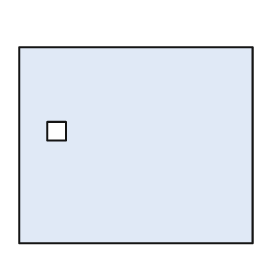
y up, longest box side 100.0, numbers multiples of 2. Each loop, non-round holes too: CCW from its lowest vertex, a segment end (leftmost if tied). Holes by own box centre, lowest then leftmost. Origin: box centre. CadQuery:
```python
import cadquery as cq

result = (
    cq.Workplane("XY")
    .moveTo(-50.0, -42.0)
    .lineTo(50.0, -42.0)
    .lineTo(50.0, 42.0)
    .lineTo(-50.0, 42.0)
    .close()
    .moveTo(-38.0, 2.0)
    .lineTo(-30.0, 2.0)
    .lineTo(-30.0, 10.0)
    .lineTo(-38.0, 10.0)
    .close()
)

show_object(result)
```